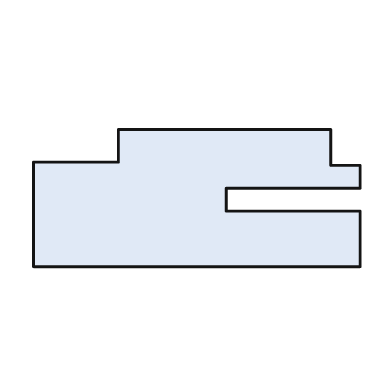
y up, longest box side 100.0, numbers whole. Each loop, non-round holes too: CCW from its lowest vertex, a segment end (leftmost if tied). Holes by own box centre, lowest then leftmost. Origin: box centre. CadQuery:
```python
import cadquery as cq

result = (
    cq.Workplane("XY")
    .moveTo(-50.0, -21.0)
    .lineTo(50.0, -21.0)
    .lineTo(50.0, -4.0)
    .lineTo(9.0, -4.0)
    .lineTo(9.0, 3.0)
    .lineTo(50.0, 3.0)
    .lineTo(50.0, 10.0)
    .lineTo(41.0, 10.0)
    .lineTo(41.0, 21.0)
    .lineTo(-24.0, 21.0)
    .lineTo(-24.0, 11.0)
    .lineTo(-50.0, 11.0)
    .close()
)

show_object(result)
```